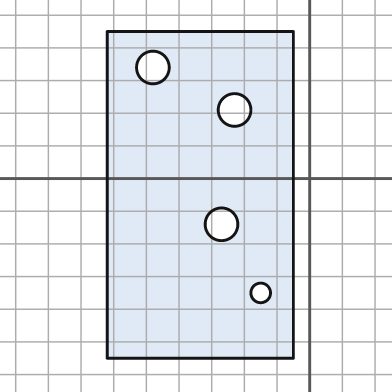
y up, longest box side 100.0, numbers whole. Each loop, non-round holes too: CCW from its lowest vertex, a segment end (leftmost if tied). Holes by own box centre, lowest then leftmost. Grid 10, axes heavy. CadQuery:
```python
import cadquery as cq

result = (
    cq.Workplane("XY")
    .moveTo(-62.0, -55.0)
    .lineTo(-5.0, -55.0)
    .lineTo(-5.0, 45.0)
    .lineTo(-62.0, 45.0)
    .close()
    .moveTo(-15.0, -35.0)
    .circle(3.0)
    .moveTo(-27.0, -14.0)
    .circle(5.0)
    .moveTo(-23.0, 21.0)
    .circle(5.0)
    .moveTo(-48.0, 34.0)
    .circle(5.0)
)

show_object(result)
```